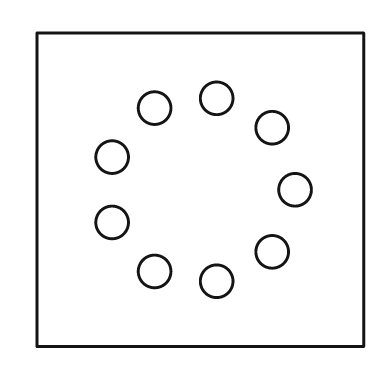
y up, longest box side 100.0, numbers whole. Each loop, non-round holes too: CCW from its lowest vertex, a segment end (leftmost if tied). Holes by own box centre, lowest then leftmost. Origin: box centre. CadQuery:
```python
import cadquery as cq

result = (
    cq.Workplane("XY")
    .moveTo(-50.0, -48.0)
    .lineTo(50.0, -48.0)
    .lineTo(50.0, 48.0)
    .lineTo(-50.0, 48.0)
    .close()
    .moveTo(5.0, -28.0)
    .circle(5.0)
    .moveTo(-14.0, -25.0)
    .circle(5.0)
    .moveTo(22.0, -19.0)
    .circle(5.0)
    .moveTo(-27.0, -10.0)
    .circle(5.0)
    .moveTo(29.0, 0.0)
    .circle(5.0)
    .moveTo(-27.0, 10.0)
    .circle(5.0)
    .moveTo(22.0, 19.0)
    .circle(5.0)
    .moveTo(-14.0, 25.0)
    .circle(5.0)
    .moveTo(5.0, 28.0)
    .circle(5.0)
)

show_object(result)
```